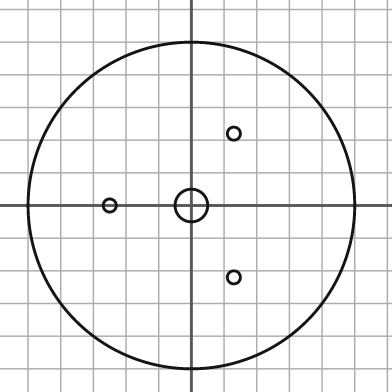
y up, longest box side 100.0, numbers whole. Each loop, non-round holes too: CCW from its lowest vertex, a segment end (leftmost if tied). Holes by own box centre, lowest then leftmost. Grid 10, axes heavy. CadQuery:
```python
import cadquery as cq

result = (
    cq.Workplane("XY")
    .moveTo(0.0, 0.0)
    .circle(50.0)
    .moveTo(13.0, -22.0)
    .circle(2.0)
    .moveTo(-25.0, 0.0)
    .circle(2.0)
    .moveTo(0.0, 0.0)
    .circle(5.0)
    .moveTo(13.0, 22.0)
    .circle(2.0)
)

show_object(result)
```